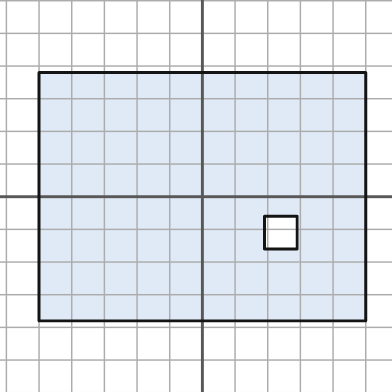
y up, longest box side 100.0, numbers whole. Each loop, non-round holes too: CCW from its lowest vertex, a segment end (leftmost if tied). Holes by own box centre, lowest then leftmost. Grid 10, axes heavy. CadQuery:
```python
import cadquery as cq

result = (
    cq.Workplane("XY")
    .moveTo(-50.0, -38.0)
    .lineTo(50.0, -38.0)
    .lineTo(50.0, 38.0)
    .lineTo(-50.0, 38.0)
    .close()
    .moveTo(19.0, -16.0)
    .lineTo(29.0, -16.0)
    .lineTo(29.0, -6.0)
    .lineTo(19.0, -6.0)
    .close()
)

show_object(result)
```